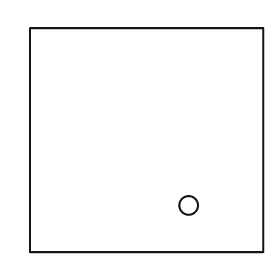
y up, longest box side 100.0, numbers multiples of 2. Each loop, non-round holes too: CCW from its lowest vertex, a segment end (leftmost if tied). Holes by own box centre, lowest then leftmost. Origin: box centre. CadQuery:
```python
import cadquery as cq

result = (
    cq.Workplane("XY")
    .moveTo(-50.0, -48.0)
    .lineTo(50.0, -48.0)
    .lineTo(50.0, 48.0)
    .lineTo(-50.0, 48.0)
    .close()
    .moveTo(18.0, -28.0)
    .circle(4.0)
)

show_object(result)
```